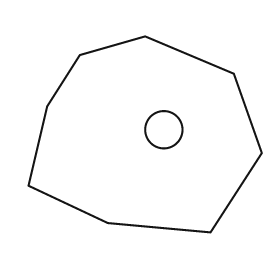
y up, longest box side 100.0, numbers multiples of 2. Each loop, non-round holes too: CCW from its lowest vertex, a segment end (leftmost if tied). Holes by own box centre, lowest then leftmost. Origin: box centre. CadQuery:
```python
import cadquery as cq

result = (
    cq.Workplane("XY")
    .moveTo(28.0, -42.0)
    .lineTo(50.0, -8.0)
    .lineTo(38.0, 26.0)
    .lineTo(0.0, 42.0)
    .lineTo(-28.0, 34.0)
    .lineTo(-42.0, 12.0)
    .lineTo(-50.0, -22.0)
    .lineTo(-16.0, -38.0)
    .close()
    .moveTo(8.0, 2.0)
    .circle(8.0)
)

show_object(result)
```